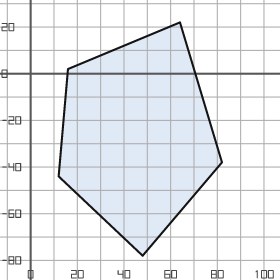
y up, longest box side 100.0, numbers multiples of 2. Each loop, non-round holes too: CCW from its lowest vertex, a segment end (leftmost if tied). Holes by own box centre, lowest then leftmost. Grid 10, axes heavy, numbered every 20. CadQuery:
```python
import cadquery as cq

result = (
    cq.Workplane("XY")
    .moveTo(48.0, -78.0)
    .lineTo(82.0, -38.0)
    .lineTo(64.0, 22.0)
    .lineTo(16.0, 2.0)
    .lineTo(12.0, -44.0)
    .close()
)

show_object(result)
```